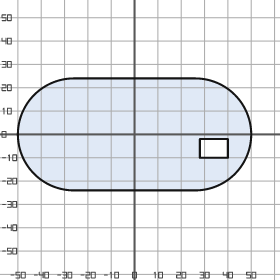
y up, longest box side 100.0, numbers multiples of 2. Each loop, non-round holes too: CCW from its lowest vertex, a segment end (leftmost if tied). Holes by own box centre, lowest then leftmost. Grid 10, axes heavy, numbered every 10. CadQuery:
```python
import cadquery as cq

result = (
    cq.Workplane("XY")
    .moveTo(-26.0, -24.0)
    .lineTo(26.0, -24.0)
    .threePointArc((50.0, 0.0), (26.0, 24.0))
    .lineTo(-26.0, 24.0)
    .threePointArc((-50.0, 0.0), (-26.0, -24.0))
    .close()
    .moveTo(28.0, -10.0)
    .lineTo(40.0, -10.0)
    .lineTo(40.0, -2.0)
    .lineTo(28.0, -2.0)
    .close()
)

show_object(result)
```